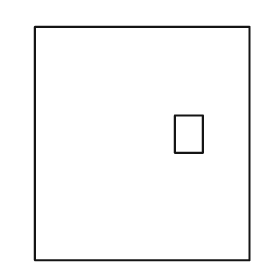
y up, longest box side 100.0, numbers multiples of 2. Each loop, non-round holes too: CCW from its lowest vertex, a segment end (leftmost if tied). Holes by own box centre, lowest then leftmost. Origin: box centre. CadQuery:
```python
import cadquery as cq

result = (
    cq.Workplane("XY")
    .moveTo(-46.0, -50.0)
    .lineTo(46.0, -50.0)
    .lineTo(46.0, 50.0)
    .lineTo(-46.0, 50.0)
    .close()
    .moveTo(14.0, -4.0)
    .lineTo(26.0, -4.0)
    .lineTo(26.0, 12.0)
    .lineTo(14.0, 12.0)
    .close()
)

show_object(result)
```